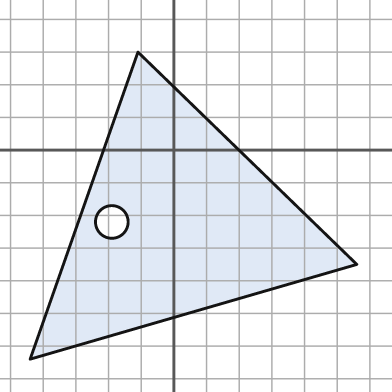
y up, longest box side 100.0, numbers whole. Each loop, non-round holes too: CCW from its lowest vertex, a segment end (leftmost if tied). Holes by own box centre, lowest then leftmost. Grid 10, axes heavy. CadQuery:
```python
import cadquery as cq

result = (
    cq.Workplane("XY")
    .moveTo(-44.0, -64.0)
    .lineTo(56.0, -35.0)
    .lineTo(-11.0, 30.0)
    .close()
    .moveTo(-19.0, -22.0)
    .circle(5.0)
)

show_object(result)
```